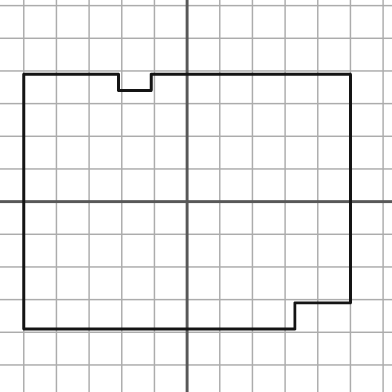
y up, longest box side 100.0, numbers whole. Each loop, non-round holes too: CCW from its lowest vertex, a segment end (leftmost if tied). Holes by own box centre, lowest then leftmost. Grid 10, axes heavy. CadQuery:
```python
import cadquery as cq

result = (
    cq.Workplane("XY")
    .moveTo(-50.0, -39.0)
    .lineTo(33.0, -39.0)
    .lineTo(33.0, -31.0)
    .lineTo(50.0, -31.0)
    .lineTo(50.0, 39.0)
    .lineTo(-11.0, 39.0)
    .lineTo(-11.0, 34.0)
    .lineTo(-21.0, 34.0)
    .lineTo(-21.0, 39.0)
    .lineTo(-50.0, 39.0)
    .close()
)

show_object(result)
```